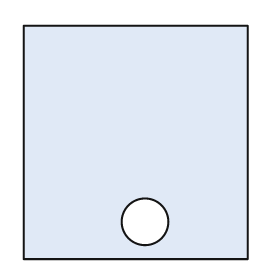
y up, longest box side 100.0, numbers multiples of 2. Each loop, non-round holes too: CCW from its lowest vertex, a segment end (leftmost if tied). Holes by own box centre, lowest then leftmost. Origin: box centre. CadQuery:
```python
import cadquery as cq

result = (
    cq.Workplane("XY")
    .moveTo(-48.0, -50.0)
    .lineTo(48.0, -50.0)
    .lineTo(48.0, 50.0)
    .lineTo(-48.0, 50.0)
    .close()
    .moveTo(4.0, -34.0)
    .circle(10.0)
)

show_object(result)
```